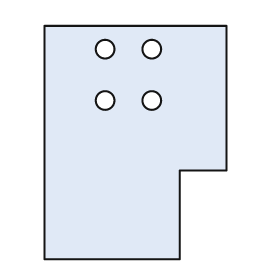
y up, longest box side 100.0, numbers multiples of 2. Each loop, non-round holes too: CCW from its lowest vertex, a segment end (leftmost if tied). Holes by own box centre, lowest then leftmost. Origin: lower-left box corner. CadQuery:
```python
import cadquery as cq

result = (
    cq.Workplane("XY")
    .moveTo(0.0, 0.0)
    .lineTo(58.0, 0.0)
    .lineTo(58.0, 38.0)
    .lineTo(78.0, 38.0)
    .lineTo(78.0, 100.0)
    .lineTo(0.0, 100.0)
    .close()
    .moveTo(26.0, 68.0)
    .circle(4.0)
    .moveTo(46.0, 68.0)
    .circle(4.0)
    .moveTo(26.0, 90.0)
    .circle(4.0)
    .moveTo(46.0, 90.0)
    .circle(4.0)
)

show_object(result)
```